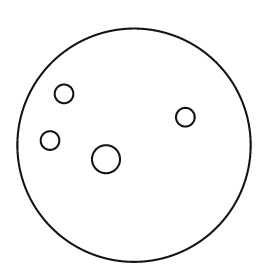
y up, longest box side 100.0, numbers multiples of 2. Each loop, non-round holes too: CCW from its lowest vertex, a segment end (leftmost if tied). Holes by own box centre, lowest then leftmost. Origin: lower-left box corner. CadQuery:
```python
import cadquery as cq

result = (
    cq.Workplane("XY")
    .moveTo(50.0, 50.0)
    .circle(50.0)
    .moveTo(38.0, 44.0)
    .circle(6.0)
    .moveTo(14.0, 52.0)
    .circle(4.0)
    .moveTo(72.0, 62.0)
    .circle(4.0)
    .moveTo(20.0, 72.0)
    .circle(4.0)
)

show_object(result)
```